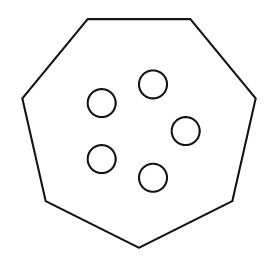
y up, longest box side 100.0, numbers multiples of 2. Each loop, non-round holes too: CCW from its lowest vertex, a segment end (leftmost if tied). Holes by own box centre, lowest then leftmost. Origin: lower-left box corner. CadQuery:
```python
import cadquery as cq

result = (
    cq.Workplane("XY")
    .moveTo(50.0, 0.0)
    .lineTo(90.0, 20.0)
    .lineTo(100.0, 64.0)
    .lineTo(72.0, 98.0)
    .lineTo(28.0, 98.0)
    .lineTo(0.0, 64.0)
    .lineTo(10.0, 20.0)
    .close()
    .moveTo(56.0, 30.0)
    .circle(6.0)
    .moveTo(34.0, 38.0)
    .circle(6.0)
    .moveTo(70.0, 50.0)
    .circle(6.0)
    .moveTo(34.0, 62.0)
    .circle(6.0)
    .moveTo(56.0, 70.0)
    .circle(6.0)
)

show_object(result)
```